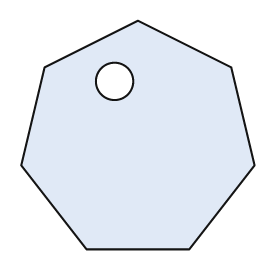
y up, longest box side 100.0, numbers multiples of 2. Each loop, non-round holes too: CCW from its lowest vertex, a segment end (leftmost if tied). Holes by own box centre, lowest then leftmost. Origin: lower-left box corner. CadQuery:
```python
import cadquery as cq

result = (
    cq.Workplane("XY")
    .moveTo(28.0, 0.0)
    .lineTo(72.0, 0.0)
    .lineTo(100.0, 36.0)
    .lineTo(90.0, 78.0)
    .lineTo(50.0, 98.0)
    .lineTo(10.0, 78.0)
    .lineTo(0.0, 36.0)
    .close()
    .moveTo(40.0, 72.0)
    .circle(8.0)
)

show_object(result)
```